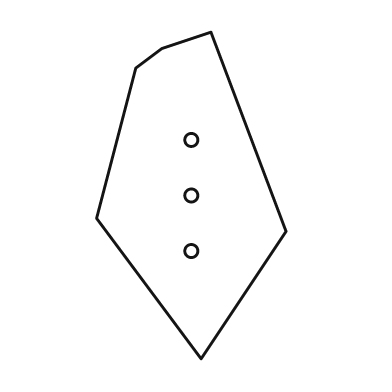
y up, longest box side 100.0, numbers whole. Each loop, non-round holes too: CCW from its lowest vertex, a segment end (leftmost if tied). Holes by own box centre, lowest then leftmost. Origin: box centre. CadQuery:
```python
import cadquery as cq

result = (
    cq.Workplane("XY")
    .moveTo(3.0, -50.0)
    .lineTo(29.0, -11.0)
    .lineTo(6.0, 50.0)
    .lineTo(-9.0, 45.0)
    .lineTo(-17.0, 39.0)
    .lineTo(-29.0, -7.0)
    .close()
    .moveTo(0.0, -17.0)
    .circle(2.0)
    .moveTo(0.0, 0.0)
    .circle(2.0)
    .moveTo(0.0, 17.0)
    .circle(2.0)
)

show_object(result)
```